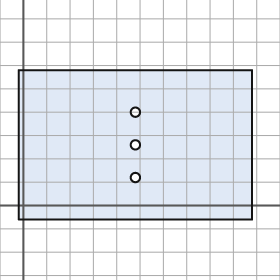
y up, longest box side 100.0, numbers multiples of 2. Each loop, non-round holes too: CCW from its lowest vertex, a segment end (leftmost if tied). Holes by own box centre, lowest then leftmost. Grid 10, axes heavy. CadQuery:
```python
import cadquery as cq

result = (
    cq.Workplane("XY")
    .moveTo(-2.0, -6.0)
    .lineTo(98.0, -6.0)
    .lineTo(98.0, 58.0)
    .lineTo(-2.0, 58.0)
    .close()
    .moveTo(48.0, 12.0)
    .circle(2.0)
    .moveTo(48.0, 26.0)
    .circle(2.0)
    .moveTo(48.0, 40.0)
    .circle(2.0)
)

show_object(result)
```